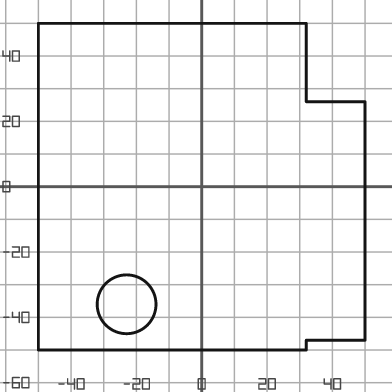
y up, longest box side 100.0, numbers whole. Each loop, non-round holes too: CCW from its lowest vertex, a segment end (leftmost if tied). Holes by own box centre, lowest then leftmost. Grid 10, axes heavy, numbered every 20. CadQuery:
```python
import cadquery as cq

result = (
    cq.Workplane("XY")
    .moveTo(-50.0, -50.0)
    .lineTo(32.0, -50.0)
    .lineTo(32.0, -47.0)
    .lineTo(50.0, -47.0)
    .lineTo(50.0, 26.0)
    .lineTo(32.0, 26.0)
    .lineTo(32.0, 50.0)
    .lineTo(-50.0, 50.0)
    .close()
    .moveTo(-23.0, -36.0)
    .circle(9.0)
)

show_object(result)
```